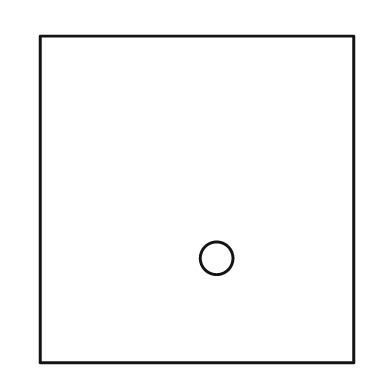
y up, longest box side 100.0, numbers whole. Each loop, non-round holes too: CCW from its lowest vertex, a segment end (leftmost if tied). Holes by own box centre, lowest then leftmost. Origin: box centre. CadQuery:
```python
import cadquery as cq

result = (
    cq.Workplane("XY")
    .moveTo(-48.0, -50.0)
    .lineTo(48.0, -50.0)
    .lineTo(48.0, 50.0)
    .lineTo(-48.0, 50.0)
    .close()
    .moveTo(6.0, -18.0)
    .circle(5.0)
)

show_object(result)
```